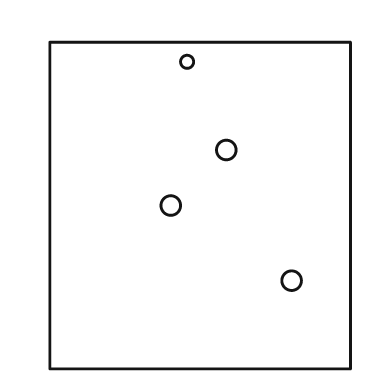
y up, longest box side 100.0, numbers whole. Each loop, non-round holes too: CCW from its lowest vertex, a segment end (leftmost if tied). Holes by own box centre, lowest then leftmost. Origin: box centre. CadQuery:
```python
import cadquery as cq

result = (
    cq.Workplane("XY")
    .moveTo(-46.0, -50.0)
    .lineTo(46.0, -50.0)
    .lineTo(46.0, 50.0)
    .lineTo(-46.0, 50.0)
    .close()
    .moveTo(28.0, -23.0)
    .circle(3.0)
    .moveTo(-9.0, 0.0)
    .circle(3.0)
    .moveTo(8.0, 17.0)
    .circle(3.0)
    .moveTo(-4.0, 44.0)
    .circle(2.0)
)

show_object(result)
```